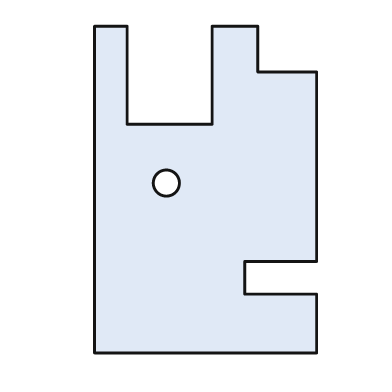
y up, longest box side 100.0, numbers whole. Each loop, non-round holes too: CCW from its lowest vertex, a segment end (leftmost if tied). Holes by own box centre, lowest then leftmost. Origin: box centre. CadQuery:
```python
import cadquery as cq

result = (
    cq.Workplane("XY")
    .moveTo(-34.0, -50.0)
    .lineTo(34.0, -50.0)
    .lineTo(34.0, -32.0)
    .lineTo(12.0, -32.0)
    .lineTo(12.0, -22.0)
    .lineTo(34.0, -22.0)
    .lineTo(34.0, 36.0)
    .lineTo(16.0, 36.0)
    .lineTo(16.0, 50.0)
    .lineTo(2.0, 50.0)
    .lineTo(2.0, 20.0)
    .lineTo(-24.0, 20.0)
    .lineTo(-24.0, 50.0)
    .lineTo(-34.0, 50.0)
    .close()
    .moveTo(-12.0, 2.0)
    .circle(4.0)
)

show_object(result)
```